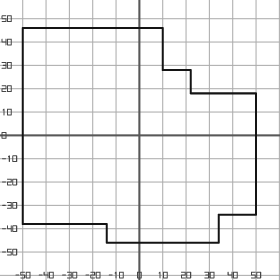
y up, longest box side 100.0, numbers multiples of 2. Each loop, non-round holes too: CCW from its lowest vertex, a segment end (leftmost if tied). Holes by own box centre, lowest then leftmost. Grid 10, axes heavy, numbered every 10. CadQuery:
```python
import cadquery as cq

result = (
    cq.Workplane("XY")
    .moveTo(-14.0, -46.0)
    .lineTo(34.0, -46.0)
    .lineTo(34.0, -34.0)
    .lineTo(50.0, -34.0)
    .lineTo(50.0, 18.0)
    .lineTo(22.0, 18.0)
    .lineTo(22.0, 28.0)
    .lineTo(10.0, 28.0)
    .lineTo(10.0, 46.0)
    .lineTo(-50.0, 46.0)
    .lineTo(-50.0, -38.0)
    .lineTo(-14.0, -38.0)
    .close()
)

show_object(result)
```